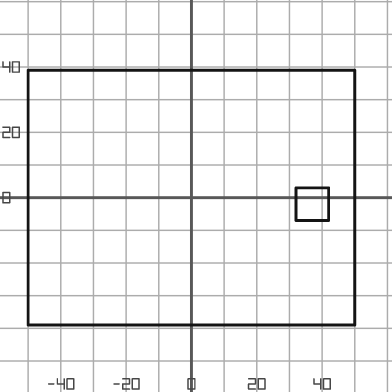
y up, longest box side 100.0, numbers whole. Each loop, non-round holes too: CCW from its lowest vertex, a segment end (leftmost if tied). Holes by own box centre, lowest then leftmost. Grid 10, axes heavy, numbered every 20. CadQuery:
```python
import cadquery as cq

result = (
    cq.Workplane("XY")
    .moveTo(-50.0, -39.0)
    .lineTo(50.0, -39.0)
    .lineTo(50.0, 39.0)
    .lineTo(-50.0, 39.0)
    .close()
    .moveTo(32.0, -7.0)
    .lineTo(42.0, -7.0)
    .lineTo(42.0, 3.0)
    .lineTo(32.0, 3.0)
    .close()
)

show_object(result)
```